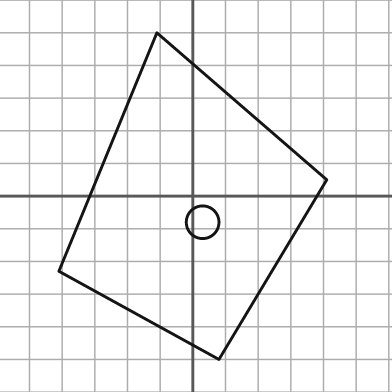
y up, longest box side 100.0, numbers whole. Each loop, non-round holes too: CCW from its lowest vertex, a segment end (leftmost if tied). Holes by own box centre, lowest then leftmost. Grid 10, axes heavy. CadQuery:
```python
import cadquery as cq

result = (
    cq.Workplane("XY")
    .moveTo(8.0, -50.0)
    .lineTo(41.0, 5.0)
    .lineTo(-11.0, 50.0)
    .lineTo(-41.0, -23.0)
    .close()
    .moveTo(3.0, -8.0)
    .circle(5.0)
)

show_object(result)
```